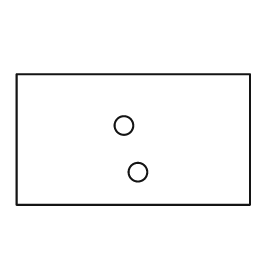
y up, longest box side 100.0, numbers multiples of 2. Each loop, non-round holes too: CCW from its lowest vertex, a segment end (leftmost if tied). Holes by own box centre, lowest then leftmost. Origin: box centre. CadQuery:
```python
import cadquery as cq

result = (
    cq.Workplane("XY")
    .moveTo(-50.0, -28.0)
    .lineTo(50.0, -28.0)
    .lineTo(50.0, 28.0)
    .lineTo(-50.0, 28.0)
    .close()
    .moveTo(2.0, -14.0)
    .circle(4.0)
    .moveTo(-4.0, 6.0)
    .circle(4.0)
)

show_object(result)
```